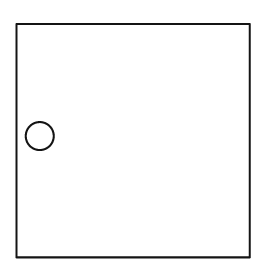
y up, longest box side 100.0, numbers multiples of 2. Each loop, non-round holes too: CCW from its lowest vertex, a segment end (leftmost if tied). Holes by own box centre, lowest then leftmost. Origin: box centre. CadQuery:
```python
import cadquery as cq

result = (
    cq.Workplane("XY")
    .moveTo(-50.0, -50.0)
    .lineTo(50.0, -50.0)
    .lineTo(50.0, 50.0)
    .lineTo(-50.0, 50.0)
    .close()
    .moveTo(-40.0, 2.0)
    .circle(6.0)
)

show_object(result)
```